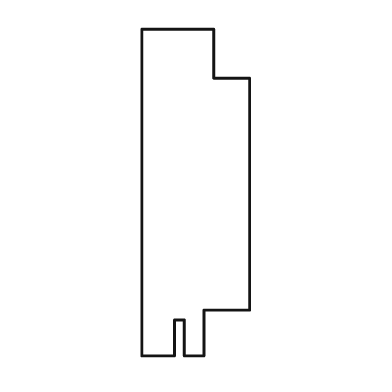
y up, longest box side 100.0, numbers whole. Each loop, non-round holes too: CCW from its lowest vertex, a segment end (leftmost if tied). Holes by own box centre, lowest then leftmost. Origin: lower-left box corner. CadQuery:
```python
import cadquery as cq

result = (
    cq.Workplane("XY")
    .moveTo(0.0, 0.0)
    .lineTo(10.0, 0.0)
    .lineTo(10.0, 11.0)
    .lineTo(13.0, 11.0)
    .lineTo(13.0, 0.0)
    .lineTo(19.0, 0.0)
    .lineTo(19.0, 14.0)
    .lineTo(33.0, 14.0)
    .lineTo(33.0, 85.0)
    .lineTo(22.0, 85.0)
    .lineTo(22.0, 100.0)
    .lineTo(0.0, 100.0)
    .close()
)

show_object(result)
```